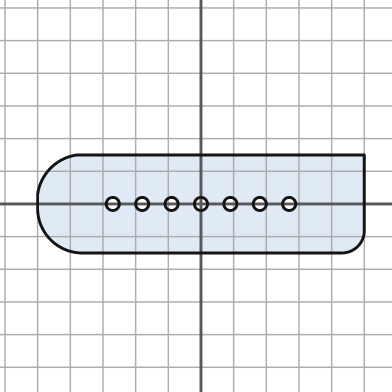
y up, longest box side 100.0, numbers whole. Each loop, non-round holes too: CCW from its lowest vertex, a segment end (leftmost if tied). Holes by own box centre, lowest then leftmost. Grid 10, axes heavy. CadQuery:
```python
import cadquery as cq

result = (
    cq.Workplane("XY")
    .moveTo(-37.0, -15.0)
    .lineTo(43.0, -15.0)
    .threePointArc((48.0, -13.0), (50.0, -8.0))
    .lineTo(50.0, 15.0)
    .lineTo(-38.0, 15.0)
    .threePointArc((-46.0, 11.0), (-50.0, 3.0))
    .lineTo(-50.0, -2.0)
    .threePointArc((-46.0, -11.0), (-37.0, -15.0))
    .close()
    .moveTo(-27.0, 0.0)
    .circle(2.0)
    .moveTo(-18.0, 0.0)
    .circle(2.0)
    .moveTo(-9.0, 0.0)
    .circle(2.0)
    .moveTo(0.0, 0.0)
    .circle(2.0)
    .moveTo(9.0, 0.0)
    .circle(2.0)
    .moveTo(18.0, 0.0)
    .circle(2.0)
    .moveTo(27.0, 0.0)
    .circle(2.0)
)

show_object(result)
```